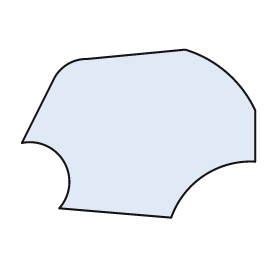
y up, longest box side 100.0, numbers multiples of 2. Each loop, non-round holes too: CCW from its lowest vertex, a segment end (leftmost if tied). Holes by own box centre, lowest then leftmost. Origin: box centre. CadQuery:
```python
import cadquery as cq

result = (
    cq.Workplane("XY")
    .moveTo(14.0, -36.0)
    .threePointArc((28.0, -18.0), (50.0, -12.0))
    .lineTo(50.0, 10.0)
    .threePointArc((38.0, 26.0), (20.0, 36.0))
    .lineTo(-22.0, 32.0)
    .threePointArc((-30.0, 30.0), (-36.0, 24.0))
    .lineTo(-50.0, -4.0)
    .threePointArc((-32.0, -12.0), (-34.0, -32.0))
    .close()
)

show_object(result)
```